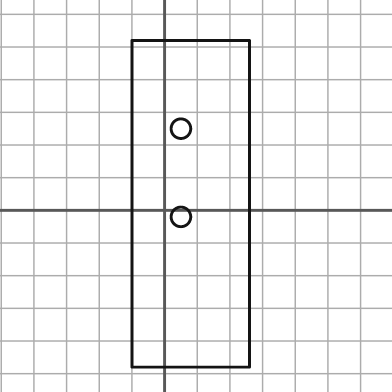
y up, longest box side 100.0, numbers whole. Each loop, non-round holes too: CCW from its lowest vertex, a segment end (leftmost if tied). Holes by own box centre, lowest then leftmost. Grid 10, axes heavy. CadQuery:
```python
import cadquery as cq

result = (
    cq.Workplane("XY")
    .moveTo(-10.0, -48.0)
    .lineTo(26.0, -48.0)
    .lineTo(26.0, 52.0)
    .lineTo(-10.0, 52.0)
    .close()
    .moveTo(5.0, -2.0)
    .circle(3.0)
    .moveTo(5.0, 25.0)
    .circle(3.0)
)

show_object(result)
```